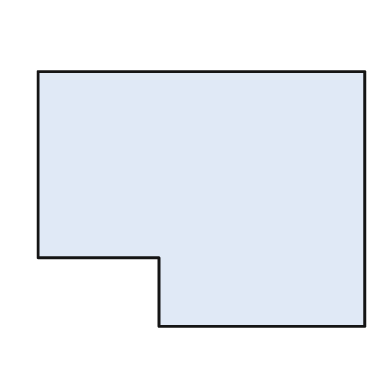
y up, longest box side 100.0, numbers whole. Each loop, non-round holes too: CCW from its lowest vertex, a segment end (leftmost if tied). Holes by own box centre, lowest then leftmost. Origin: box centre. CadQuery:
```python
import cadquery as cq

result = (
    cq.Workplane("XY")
    .moveTo(-13.0, -39.0)
    .lineTo(50.0, -39.0)
    .lineTo(50.0, 39.0)
    .lineTo(-50.0, 39.0)
    .lineTo(-50.0, -18.0)
    .lineTo(-13.0, -18.0)
    .close()
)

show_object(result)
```